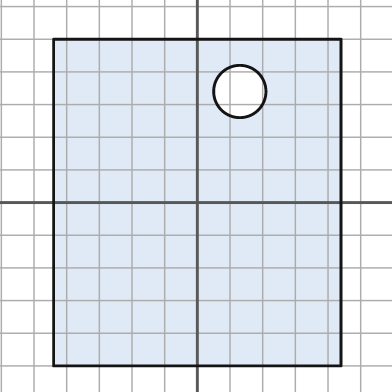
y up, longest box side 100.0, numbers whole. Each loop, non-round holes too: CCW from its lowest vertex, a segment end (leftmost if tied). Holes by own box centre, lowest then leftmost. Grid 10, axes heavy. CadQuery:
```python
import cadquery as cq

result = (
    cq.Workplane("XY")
    .moveTo(-44.0, -50.0)
    .lineTo(44.0, -50.0)
    .lineTo(44.0, 50.0)
    .lineTo(-44.0, 50.0)
    .close()
    .moveTo(13.0, 34.0)
    .circle(8.0)
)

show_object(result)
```